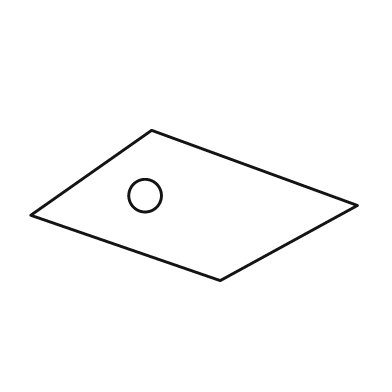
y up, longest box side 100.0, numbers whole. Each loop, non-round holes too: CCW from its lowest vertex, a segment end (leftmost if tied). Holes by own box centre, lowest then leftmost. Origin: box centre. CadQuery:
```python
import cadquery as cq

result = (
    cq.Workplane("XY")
    .moveTo(8.0, -23.0)
    .lineTo(50.0, 0.0)
    .lineTo(-13.0, 23.0)
    .lineTo(-50.0, -3.0)
    .close()
    .moveTo(-15.0, 3.0)
    .circle(5.0)
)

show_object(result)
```